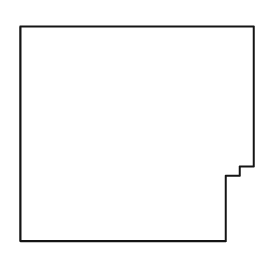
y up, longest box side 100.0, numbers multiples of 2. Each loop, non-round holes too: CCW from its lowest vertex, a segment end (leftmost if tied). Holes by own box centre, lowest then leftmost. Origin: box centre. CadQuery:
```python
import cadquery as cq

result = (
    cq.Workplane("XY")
    .moveTo(-50.0, -46.0)
    .lineTo(38.0, -46.0)
    .lineTo(38.0, -18.0)
    .lineTo(44.0, -18.0)
    .lineTo(44.0, -14.0)
    .lineTo(50.0, -14.0)
    .lineTo(50.0, 46.0)
    .lineTo(-50.0, 46.0)
    .close()
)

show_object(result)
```